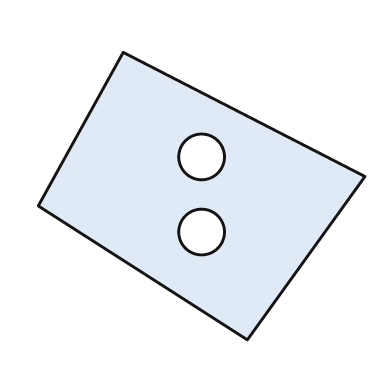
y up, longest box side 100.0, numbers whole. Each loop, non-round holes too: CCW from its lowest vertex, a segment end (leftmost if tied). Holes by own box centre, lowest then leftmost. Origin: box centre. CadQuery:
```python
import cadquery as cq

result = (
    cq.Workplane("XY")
    .moveTo(14.0, -44.0)
    .lineTo(50.0, 6.0)
    .lineTo(-24.0, 44.0)
    .lineTo(-50.0, -3.0)
    .close()
    .moveTo(0.0, -11.0)
    .circle(7.0)
    .moveTo(0.0, 12.0)
    .circle(7.0)
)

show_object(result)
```